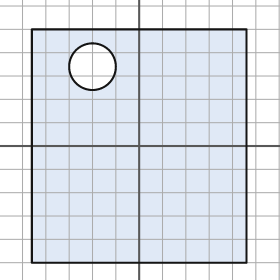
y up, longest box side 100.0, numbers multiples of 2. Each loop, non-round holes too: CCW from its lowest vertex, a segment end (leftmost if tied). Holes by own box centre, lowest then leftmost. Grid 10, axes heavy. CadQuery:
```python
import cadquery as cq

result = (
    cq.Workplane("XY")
    .moveTo(-46.0, -50.0)
    .lineTo(46.0, -50.0)
    .lineTo(46.0, 50.0)
    .lineTo(-46.0, 50.0)
    .close()
    .moveTo(-20.0, 34.0)
    .circle(10.0)
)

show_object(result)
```